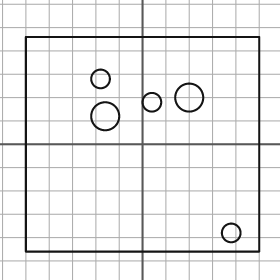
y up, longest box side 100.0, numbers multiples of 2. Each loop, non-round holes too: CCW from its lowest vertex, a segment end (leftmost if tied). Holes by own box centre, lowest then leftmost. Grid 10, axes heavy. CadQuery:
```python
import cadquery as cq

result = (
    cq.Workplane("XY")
    .moveTo(-50.0, -46.0)
    .lineTo(50.0, -46.0)
    .lineTo(50.0, 46.0)
    .lineTo(-50.0, 46.0)
    .close()
    .moveTo(38.0, -38.0)
    .circle(4.0)
    .moveTo(-16.0, 12.0)
    .circle(6.0)
    .moveTo(4.0, 18.0)
    .circle(4.0)
    .moveTo(20.0, 20.0)
    .circle(6.0)
    .moveTo(-18.0, 28.0)
    .circle(4.0)
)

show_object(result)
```